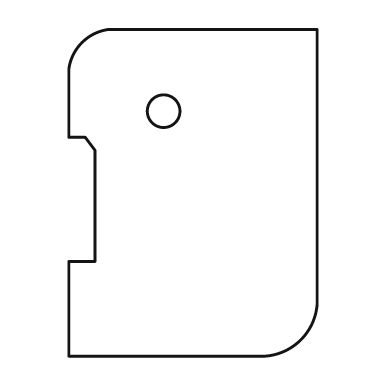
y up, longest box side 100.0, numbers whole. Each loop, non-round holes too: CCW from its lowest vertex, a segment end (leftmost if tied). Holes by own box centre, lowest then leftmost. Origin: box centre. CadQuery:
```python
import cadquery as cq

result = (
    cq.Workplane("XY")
    .moveTo(-38.0, -50.0)
    .lineTo(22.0, -50.0)
    .threePointArc((33.0, -45.0), (38.0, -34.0))
    .lineTo(38.0, 50.0)
    .lineTo(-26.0, 50.0)
    .threePointArc((-34.0, 46.0), (-38.0, 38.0))
    .lineTo(-38.0, 17.0)
    .lineTo(-33.0, 17.0)
    .lineTo(-30.0, 13.0)
    .lineTo(-30.0, -21.0)
    .lineTo(-38.0, -21.0)
    .close()
    .moveTo(-9.0, 25.0)
    .circle(5.0)
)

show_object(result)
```